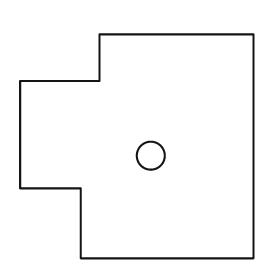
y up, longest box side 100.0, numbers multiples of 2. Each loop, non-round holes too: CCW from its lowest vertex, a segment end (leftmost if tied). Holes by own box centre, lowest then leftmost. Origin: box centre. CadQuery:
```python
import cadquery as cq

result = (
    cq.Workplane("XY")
    .moveTo(-24.0, -48.0)
    .lineTo(50.0, -48.0)
    .lineTo(50.0, 48.0)
    .lineTo(-16.0, 48.0)
    .lineTo(-16.0, 28.0)
    .lineTo(-50.0, 28.0)
    .lineTo(-50.0, -18.0)
    .lineTo(-24.0, -18.0)
    .close()
    .moveTo(6.0, -4.0)
    .circle(6.0)
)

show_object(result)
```